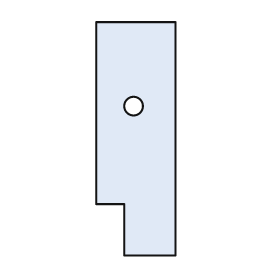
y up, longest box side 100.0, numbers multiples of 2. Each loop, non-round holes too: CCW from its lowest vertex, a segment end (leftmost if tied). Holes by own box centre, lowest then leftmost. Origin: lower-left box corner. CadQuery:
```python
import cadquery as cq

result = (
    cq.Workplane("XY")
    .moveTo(12.0, 0.0)
    .lineTo(34.0, 0.0)
    .lineTo(34.0, 100.0)
    .lineTo(0.0, 100.0)
    .lineTo(0.0, 22.0)
    .lineTo(12.0, 22.0)
    .close()
    .moveTo(16.0, 64.0)
    .circle(4.0)
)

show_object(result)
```